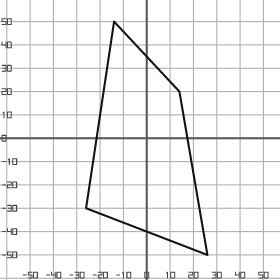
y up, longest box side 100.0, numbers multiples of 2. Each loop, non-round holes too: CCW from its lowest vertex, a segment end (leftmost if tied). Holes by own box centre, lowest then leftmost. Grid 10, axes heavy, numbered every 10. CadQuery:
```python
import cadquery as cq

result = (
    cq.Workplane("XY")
    .moveTo(26.0, -50.0)
    .lineTo(14.0, 20.0)
    .lineTo(-14.0, 50.0)
    .lineTo(-26.0, -30.0)
    .close()
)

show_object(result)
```